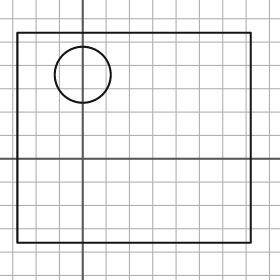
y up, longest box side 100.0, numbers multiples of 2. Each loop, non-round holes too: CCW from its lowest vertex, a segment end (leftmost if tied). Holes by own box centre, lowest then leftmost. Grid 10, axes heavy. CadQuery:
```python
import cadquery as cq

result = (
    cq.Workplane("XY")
    .moveTo(-28.0, -36.0)
    .lineTo(72.0, -36.0)
    .lineTo(72.0, 54.0)
    .lineTo(-28.0, 54.0)
    .close()
    .moveTo(0.0, 36.0)
    .circle(12.0)
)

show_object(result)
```